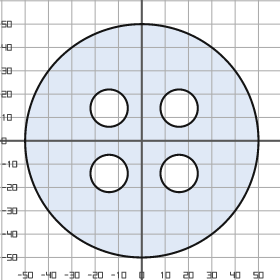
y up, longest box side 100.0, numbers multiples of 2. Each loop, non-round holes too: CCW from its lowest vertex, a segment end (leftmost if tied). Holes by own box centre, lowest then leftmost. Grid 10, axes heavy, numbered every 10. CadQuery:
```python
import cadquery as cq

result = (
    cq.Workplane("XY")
    .moveTo(0.0, 0.0)
    .circle(50.0)
    .moveTo(-14.0, -14.0)
    .circle(8.0)
    .moveTo(16.0, -14.0)
    .circle(8.0)
    .moveTo(-14.0, 14.0)
    .circle(8.0)
    .moveTo(16.0, 14.0)
    .circle(8.0)
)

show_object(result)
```